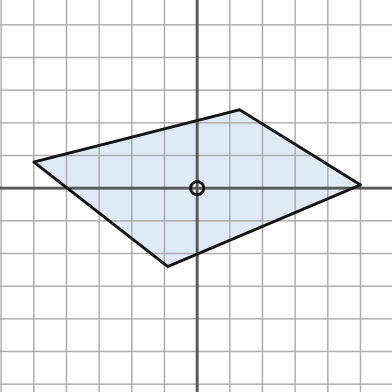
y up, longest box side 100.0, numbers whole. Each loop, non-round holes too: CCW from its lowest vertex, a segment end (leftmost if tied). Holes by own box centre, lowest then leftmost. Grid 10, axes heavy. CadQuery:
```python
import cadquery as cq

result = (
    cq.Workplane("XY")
    .moveTo(-9.0, -24.0)
    .lineTo(50.0, 1.0)
    .lineTo(13.0, 24.0)
    .lineTo(-50.0, 8.0)
    .close()
    .moveTo(0.0, 0.0)
    .circle(2.0)
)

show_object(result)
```